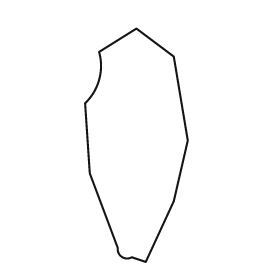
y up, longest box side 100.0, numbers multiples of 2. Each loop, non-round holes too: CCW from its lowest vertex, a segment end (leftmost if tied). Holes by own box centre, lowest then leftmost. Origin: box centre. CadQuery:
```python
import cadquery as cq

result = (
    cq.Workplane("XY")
    .moveTo(4.0, -50.0)
    .lineTo(16.0, -24.0)
    .lineTo(22.0, 2.0)
    .lineTo(16.0, 38.0)
    .lineTo(0.0, 50.0)
    .lineTo(-16.0, 40.0)
    .threePointArc((-16.0, 28.0), (-22.0, 18.0))
    .lineTo(-20.0, -12.0)
    .lineTo(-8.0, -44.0)
    .threePointArc((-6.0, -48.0), (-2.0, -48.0))
    .close()
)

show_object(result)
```